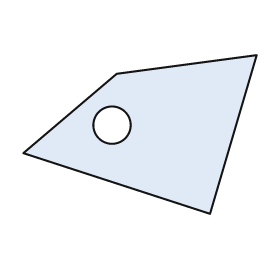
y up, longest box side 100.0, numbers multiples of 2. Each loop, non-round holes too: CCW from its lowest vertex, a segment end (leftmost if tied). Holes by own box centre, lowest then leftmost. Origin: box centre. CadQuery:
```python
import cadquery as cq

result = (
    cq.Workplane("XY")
    .moveTo(30.0, -34.0)
    .lineTo(50.0, 34.0)
    .lineTo(-10.0, 26.0)
    .lineTo(-50.0, -8.0)
    .close()
    .moveTo(-12.0, 4.0)
    .circle(8.0)
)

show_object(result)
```